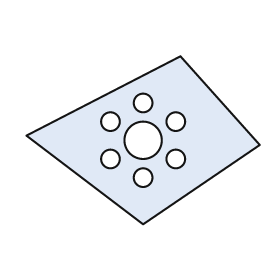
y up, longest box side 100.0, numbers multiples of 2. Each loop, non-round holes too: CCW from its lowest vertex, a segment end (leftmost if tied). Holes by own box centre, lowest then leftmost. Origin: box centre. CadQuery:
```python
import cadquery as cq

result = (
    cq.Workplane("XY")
    .moveTo(0.0, -36.0)
    .lineTo(50.0, -2.0)
    .lineTo(16.0, 36.0)
    .lineTo(-50.0, 2.0)
    .close()
    .moveTo(0.0, -16.0)
    .circle(4.0)
    .moveTo(-14.0, -8.0)
    .circle(4.0)
    .moveTo(14.0, -8.0)
    .circle(4.0)
    .moveTo(0.0, 0.0)
    .circle(8.0)
    .moveTo(-14.0, 8.0)
    .circle(4.0)
    .moveTo(14.0, 8.0)
    .circle(4.0)
    .moveTo(0.0, 16.0)
    .circle(4.0)
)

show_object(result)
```